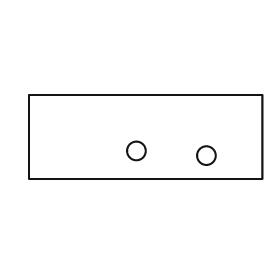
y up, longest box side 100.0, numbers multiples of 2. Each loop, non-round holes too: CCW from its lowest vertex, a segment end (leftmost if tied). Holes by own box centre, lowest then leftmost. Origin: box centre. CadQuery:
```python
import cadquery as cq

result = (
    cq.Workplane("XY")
    .moveTo(-50.0, -18.0)
    .lineTo(50.0, -18.0)
    .lineTo(50.0, 18.0)
    .lineTo(-50.0, 18.0)
    .close()
    .moveTo(26.0, -8.0)
    .circle(4.0)
    .moveTo(-4.0, -6.0)
    .circle(4.0)
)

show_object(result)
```